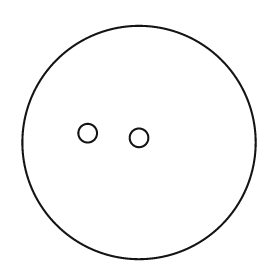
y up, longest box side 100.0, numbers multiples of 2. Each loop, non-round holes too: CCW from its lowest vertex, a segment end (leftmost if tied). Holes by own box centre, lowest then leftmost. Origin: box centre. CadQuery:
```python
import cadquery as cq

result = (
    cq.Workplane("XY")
    .moveTo(0.0, 0.0)
    .circle(50.0)
    .moveTo(0.0, 2.0)
    .circle(4.0)
    .moveTo(-22.0, 4.0)
    .circle(4.0)
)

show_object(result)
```